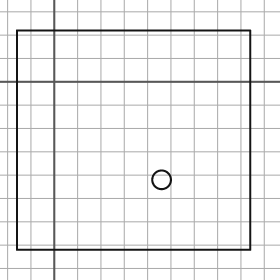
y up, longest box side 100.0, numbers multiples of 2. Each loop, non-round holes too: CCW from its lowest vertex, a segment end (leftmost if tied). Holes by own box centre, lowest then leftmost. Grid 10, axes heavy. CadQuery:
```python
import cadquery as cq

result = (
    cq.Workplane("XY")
    .moveTo(-16.0, -72.0)
    .lineTo(84.0, -72.0)
    .lineTo(84.0, 22.0)
    .lineTo(-16.0, 22.0)
    .close()
    .moveTo(46.0, -42.0)
    .circle(4.0)
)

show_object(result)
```